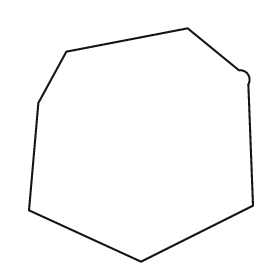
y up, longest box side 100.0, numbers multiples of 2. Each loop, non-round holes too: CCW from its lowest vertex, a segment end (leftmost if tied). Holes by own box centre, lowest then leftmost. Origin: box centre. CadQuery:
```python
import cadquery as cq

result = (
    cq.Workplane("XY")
    .moveTo(0.0, -50.0)
    .lineTo(48.0, -26.0)
    .lineTo(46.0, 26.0)
    .threePointArc((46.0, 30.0), (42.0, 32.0))
    .lineTo(20.0, 50.0)
    .lineTo(-32.0, 40.0)
    .lineTo(-44.0, 18.0)
    .lineTo(-48.0, -28.0)
    .close()
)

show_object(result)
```